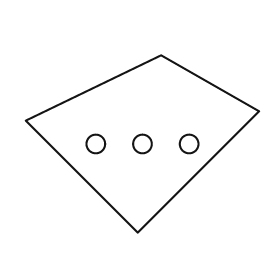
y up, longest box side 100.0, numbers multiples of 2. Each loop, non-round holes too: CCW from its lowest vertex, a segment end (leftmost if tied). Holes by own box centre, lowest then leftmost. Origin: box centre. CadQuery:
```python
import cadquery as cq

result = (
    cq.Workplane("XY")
    .moveTo(-2.0, -38.0)
    .lineTo(50.0, 14.0)
    .lineTo(8.0, 38.0)
    .lineTo(-50.0, 10.0)
    .close()
    .moveTo(-20.0, 0.0)
    .circle(4.0)
    .moveTo(0.0, 0.0)
    .circle(4.0)
    .moveTo(20.0, 0.0)
    .circle(4.0)
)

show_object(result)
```